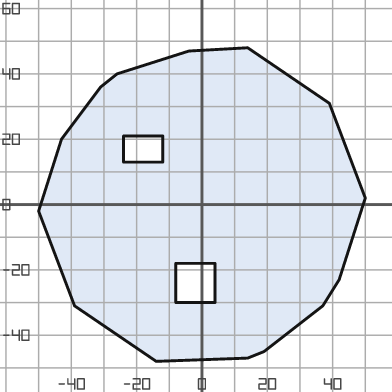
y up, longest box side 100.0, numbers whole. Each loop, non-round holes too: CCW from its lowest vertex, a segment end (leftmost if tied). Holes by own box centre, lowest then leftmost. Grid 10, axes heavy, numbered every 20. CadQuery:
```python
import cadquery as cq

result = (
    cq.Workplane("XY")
    .moveTo(-14.0, -48.0)
    .lineTo(14.0, -47.0)
    .lineTo(19.0, -45.0)
    .lineTo(37.0, -31.0)
    .lineTo(42.0, -23.0)
    .lineTo(50.0, 2.0)
    .lineTo(39.0, 31.0)
    .lineTo(14.0, 48.0)
    .lineTo(-4.0, 47.0)
    .lineTo(-26.0, 40.0)
    .lineTo(-31.0, 36.0)
    .lineTo(-43.0, 20.0)
    .lineTo(-50.0, -2.0)
    .lineTo(-39.0, -31.0)
    .close()
    .moveTo(-8.0, -30.0)
    .lineTo(4.0, -30.0)
    .lineTo(4.0, -18.0)
    .lineTo(-8.0, -18.0)
    .close()
    .moveTo(-24.0, 13.0)
    .lineTo(-12.0, 13.0)
    .lineTo(-12.0, 21.0)
    .lineTo(-24.0, 21.0)
    .close()
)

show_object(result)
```